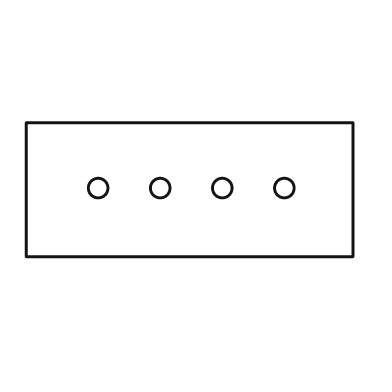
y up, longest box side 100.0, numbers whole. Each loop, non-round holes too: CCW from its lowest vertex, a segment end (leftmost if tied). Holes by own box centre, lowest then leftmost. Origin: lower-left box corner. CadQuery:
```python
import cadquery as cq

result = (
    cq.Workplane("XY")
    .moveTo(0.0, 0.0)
    .lineTo(100.0, 0.0)
    .lineTo(100.0, 41.0)
    .lineTo(0.0, 41.0)
    .close()
    .moveTo(22.0, 21.0)
    .circle(3.0)
    .moveTo(41.0, 21.0)
    .circle(3.0)
    .moveTo(60.0, 21.0)
    .circle(3.0)
    .moveTo(79.0, 21.0)
    .circle(3.0)
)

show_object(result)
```